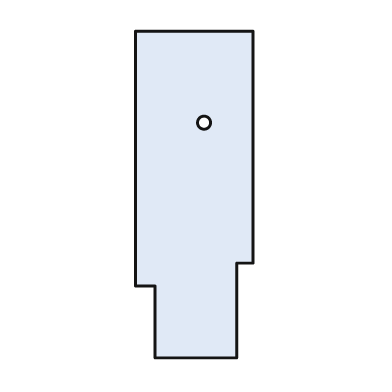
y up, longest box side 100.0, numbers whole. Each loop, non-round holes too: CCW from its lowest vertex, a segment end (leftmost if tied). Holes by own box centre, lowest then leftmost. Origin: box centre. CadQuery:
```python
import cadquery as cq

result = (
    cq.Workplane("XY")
    .moveTo(-12.0, -50.0)
    .lineTo(13.0, -50.0)
    .lineTo(13.0, -21.0)
    .lineTo(18.0, -21.0)
    .lineTo(18.0, 50.0)
    .lineTo(-18.0, 50.0)
    .lineTo(-18.0, -28.0)
    .lineTo(-12.0, -28.0)
    .close()
    .moveTo(3.0, 22.0)
    .circle(2.0)
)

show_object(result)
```